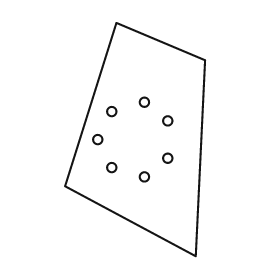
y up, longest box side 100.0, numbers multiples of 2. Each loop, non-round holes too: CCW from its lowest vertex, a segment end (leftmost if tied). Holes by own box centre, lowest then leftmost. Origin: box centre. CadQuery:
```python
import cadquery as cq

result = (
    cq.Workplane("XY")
    .moveTo(26.0, -50.0)
    .lineTo(30.0, 34.0)
    .lineTo(-8.0, 50.0)
    .lineTo(-30.0, -20.0)
    .close()
    .moveTo(4.0, -16.0)
    .circle(2.0)
    .moveTo(-10.0, -12.0)
    .circle(2.0)
    .moveTo(14.0, -8.0)
    .circle(2.0)
    .moveTo(-16.0, 0.0)
    .circle(2.0)
    .moveTo(14.0, 8.0)
    .circle(2.0)
    .moveTo(-10.0, 12.0)
    .circle(2.0)
    .moveTo(4.0, 16.0)
    .circle(2.0)
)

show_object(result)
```